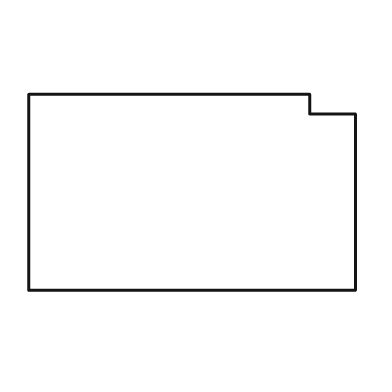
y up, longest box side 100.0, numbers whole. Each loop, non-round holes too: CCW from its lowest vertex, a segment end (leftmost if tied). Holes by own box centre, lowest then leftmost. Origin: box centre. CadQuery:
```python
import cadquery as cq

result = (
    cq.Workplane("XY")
    .moveTo(-50.0, -30.0)
    .lineTo(50.0, -30.0)
    .lineTo(50.0, 24.0)
    .lineTo(36.0, 24.0)
    .lineTo(36.0, 30.0)
    .lineTo(-50.0, 30.0)
    .close()
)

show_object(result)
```